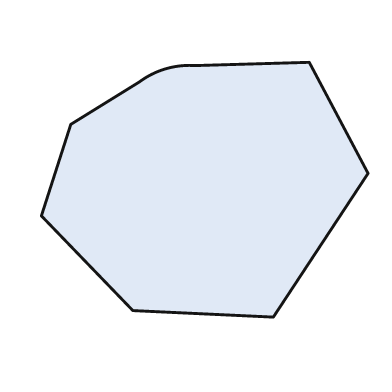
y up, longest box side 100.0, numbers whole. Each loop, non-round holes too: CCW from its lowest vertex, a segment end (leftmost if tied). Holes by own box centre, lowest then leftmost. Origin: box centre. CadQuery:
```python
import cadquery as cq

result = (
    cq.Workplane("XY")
    .moveTo(21.0, -39.0)
    .lineTo(50.0, 5.0)
    .lineTo(32.0, 39.0)
    .lineTo(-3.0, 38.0)
    .threePointArc((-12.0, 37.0), (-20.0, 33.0))
    .lineTo(-41.0, 20.0)
    .lineTo(-50.0, -8.0)
    .lineTo(-22.0, -37.0)
    .close()
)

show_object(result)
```